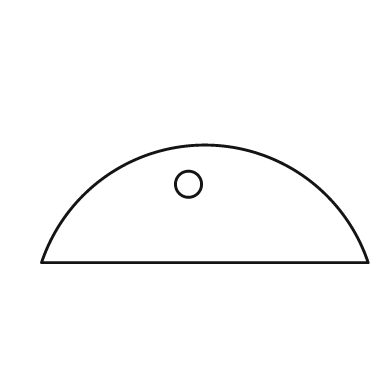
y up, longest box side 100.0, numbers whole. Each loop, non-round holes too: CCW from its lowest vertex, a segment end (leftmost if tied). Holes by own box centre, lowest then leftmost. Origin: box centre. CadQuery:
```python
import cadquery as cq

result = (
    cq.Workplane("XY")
    .moveTo(-50.0, -18.0)
    .lineTo(50.0, -18.0)
    .threePointArc((0.0, 18.0), (-50.0, -18.0))
    .close()
    .moveTo(-5.0, 6.0)
    .circle(4.0)
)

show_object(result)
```